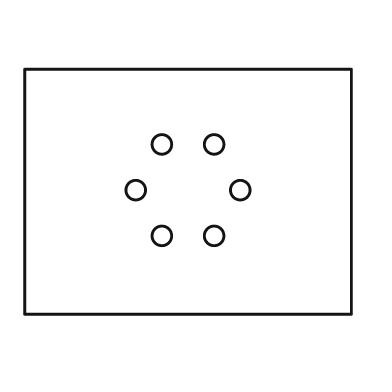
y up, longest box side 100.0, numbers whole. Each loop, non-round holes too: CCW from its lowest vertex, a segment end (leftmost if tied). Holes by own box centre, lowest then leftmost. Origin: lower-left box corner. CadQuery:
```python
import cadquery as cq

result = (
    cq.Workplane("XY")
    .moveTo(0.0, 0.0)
    .lineTo(100.0, 0.0)
    .lineTo(100.0, 75.0)
    .lineTo(0.0, 75.0)
    .close()
    .moveTo(42.0, 24.0)
    .circle(3.0)
    .moveTo(58.0, 24.0)
    .circle(3.0)
    .moveTo(34.0, 38.0)
    .circle(3.0)
    .moveTo(66.0, 38.0)
    .circle(3.0)
    .moveTo(42.0, 52.0)
    .circle(3.0)
    .moveTo(58.0, 52.0)
    .circle(3.0)
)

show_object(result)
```